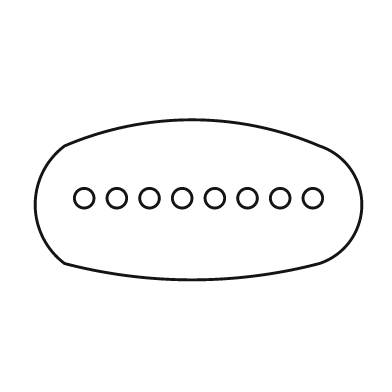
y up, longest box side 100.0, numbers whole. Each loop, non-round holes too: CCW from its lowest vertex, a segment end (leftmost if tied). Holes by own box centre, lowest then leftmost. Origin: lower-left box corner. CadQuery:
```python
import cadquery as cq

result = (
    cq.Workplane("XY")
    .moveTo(9.0, 5.0)
    .threePointArc((48.0, 0.0), (87.0, 5.0))
    .threePointArc((100.0, 23.0), (87.0, 41.0))
    .threePointArc((48.0, 49.0), (9.0, 41.0))
    .threePointArc((0.0, 23.0), (9.0, 5.0))
    .close()
    .moveTo(15.0, 25.0)
    .circle(3.0)
    .moveTo(25.0, 25.0)
    .circle(3.0)
    .moveTo(35.0, 25.0)
    .circle(3.0)
    .moveTo(45.0, 25.0)
    .circle(3.0)
    .moveTo(55.0, 25.0)
    .circle(3.0)
    .moveTo(65.0, 25.0)
    .circle(3.0)
    .moveTo(75.0, 25.0)
    .circle(3.0)
    .moveTo(85.0, 25.0)
    .circle(3.0)
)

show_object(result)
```